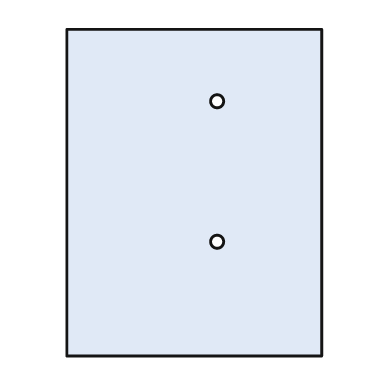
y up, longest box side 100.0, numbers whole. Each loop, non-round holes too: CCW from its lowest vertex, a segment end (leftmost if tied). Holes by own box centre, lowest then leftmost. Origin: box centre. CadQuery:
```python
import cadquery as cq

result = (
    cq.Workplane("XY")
    .moveTo(-39.0, -50.0)
    .lineTo(39.0, -50.0)
    .lineTo(39.0, 50.0)
    .lineTo(-39.0, 50.0)
    .close()
    .moveTo(7.0, -15.0)
    .circle(2.0)
    .moveTo(7.0, 28.0)
    .circle(2.0)
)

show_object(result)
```